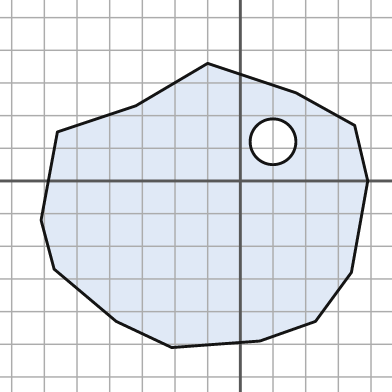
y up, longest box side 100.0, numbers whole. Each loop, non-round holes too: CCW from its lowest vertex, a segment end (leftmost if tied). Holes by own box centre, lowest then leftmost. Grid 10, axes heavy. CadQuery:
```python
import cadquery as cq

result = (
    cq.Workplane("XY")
    .moveTo(-21.0, -51.0)
    .lineTo(6.0, -49.0)
    .lineTo(23.0, -43.0)
    .lineTo(34.0, -28.0)
    .lineTo(39.0, 0.0)
    .lineTo(35.0, 17.0)
    .lineTo(17.0, 27.0)
    .lineTo(-10.0, 36.0)
    .lineTo(-32.0, 23.0)
    .lineTo(-56.0, 15.0)
    .lineTo(-61.0, -12.0)
    .lineTo(-57.0, -27.0)
    .lineTo(-38.0, -43.0)
    .close()
    .moveTo(10.0, 12.0)
    .circle(7.0)
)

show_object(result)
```